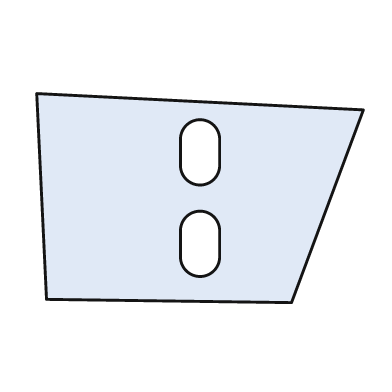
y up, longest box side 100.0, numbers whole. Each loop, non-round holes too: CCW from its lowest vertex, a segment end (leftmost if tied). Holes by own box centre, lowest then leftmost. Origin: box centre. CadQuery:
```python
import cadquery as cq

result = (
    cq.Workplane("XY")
    .moveTo(28.0, -32.0)
    .lineTo(50.0, 27.0)
    .lineTo(-50.0, 32.0)
    .lineTo(-47.0, -31.0)
    .close()
    .moveTo(-6.0, -18.0)
    .threePointArc((0.0, -24.0), (6.0, -18.0))
    .lineTo(6.0, -10.0)
    .threePointArc((0.0, -4.0), (-6.0, -10.0))
    .close()
    .moveTo(-6.0, 10.0)
    .threePointArc((0.0, 4.0), (6.0, 10.0))
    .lineTo(6.0, 18.0)
    .threePointArc((0.0, 24.0), (-6.0, 18.0))
    .close()
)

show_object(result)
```